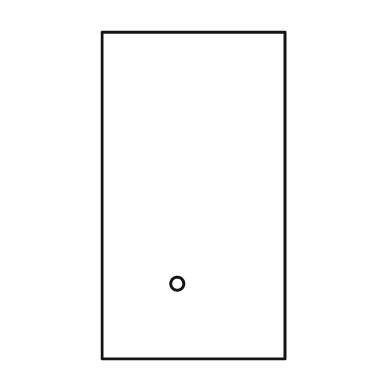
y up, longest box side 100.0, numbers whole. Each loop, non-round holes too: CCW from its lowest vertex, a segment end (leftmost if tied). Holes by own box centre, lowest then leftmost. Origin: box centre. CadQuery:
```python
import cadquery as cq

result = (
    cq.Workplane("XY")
    .moveTo(-28.0, -50.0)
    .lineTo(28.0, -50.0)
    .lineTo(28.0, 50.0)
    .lineTo(-28.0, 50.0)
    .close()
    .moveTo(-5.0, -27.0)
    .circle(2.0)
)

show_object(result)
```